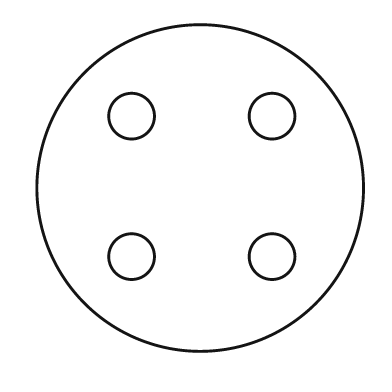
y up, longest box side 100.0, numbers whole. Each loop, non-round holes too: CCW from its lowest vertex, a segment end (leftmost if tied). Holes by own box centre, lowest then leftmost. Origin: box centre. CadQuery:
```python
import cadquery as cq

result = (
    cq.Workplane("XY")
    .moveTo(0.0, 0.0)
    .circle(50.0)
    .moveTo(-21.0, -21.0)
    .circle(7.0)
    .moveTo(22.0, -21.0)
    .circle(7.0)
    .moveTo(-21.0, 22.0)
    .circle(7.0)
    .moveTo(22.0, 22.0)
    .circle(7.0)
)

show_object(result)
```